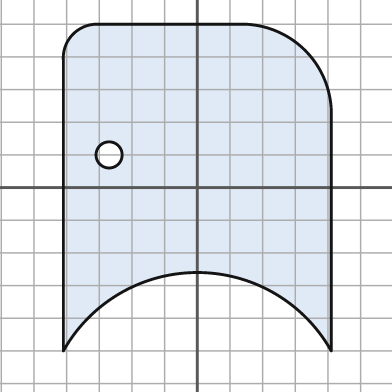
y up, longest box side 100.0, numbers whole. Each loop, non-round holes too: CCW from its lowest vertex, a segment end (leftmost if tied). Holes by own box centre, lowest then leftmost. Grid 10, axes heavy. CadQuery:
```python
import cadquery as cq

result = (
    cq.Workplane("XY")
    .moveTo(-41.0, -50.0)
    .threePointArc((0.0, -26.0), (41.0, -50.0))
    .lineTo(41.0, 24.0)
    .threePointArc((33.0, 42.0), (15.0, 50.0))
    .lineTo(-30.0, 50.0)
    .threePointArc((-38.0, 47.0), (-41.0, 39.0))
    .close()
    .moveTo(-27.0, 10.0)
    .circle(4.0)
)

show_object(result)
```